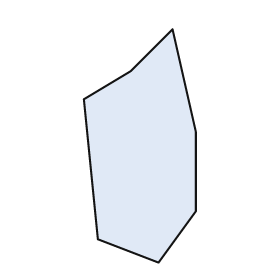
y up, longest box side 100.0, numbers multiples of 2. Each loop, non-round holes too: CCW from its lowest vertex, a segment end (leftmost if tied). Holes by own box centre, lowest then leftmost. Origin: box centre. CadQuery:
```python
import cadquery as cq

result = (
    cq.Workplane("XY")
    .moveTo(8.0, -50.0)
    .lineTo(24.0, -28.0)
    .lineTo(24.0, 6.0)
    .lineTo(14.0, 50.0)
    .lineTo(-4.0, 32.0)
    .lineTo(-24.0, 20.0)
    .lineTo(-18.0, -40.0)
    .close()
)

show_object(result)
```